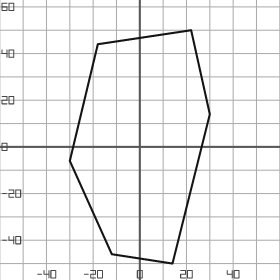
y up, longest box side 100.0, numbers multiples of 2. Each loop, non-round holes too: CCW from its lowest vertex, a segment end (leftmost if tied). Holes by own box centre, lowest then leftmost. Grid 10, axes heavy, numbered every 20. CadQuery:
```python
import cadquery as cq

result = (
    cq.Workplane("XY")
    .moveTo(14.0, -50.0)
    .lineTo(30.0, 14.0)
    .lineTo(22.0, 50.0)
    .lineTo(-18.0, 44.0)
    .lineTo(-30.0, -6.0)
    .lineTo(-12.0, -46.0)
    .close()
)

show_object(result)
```